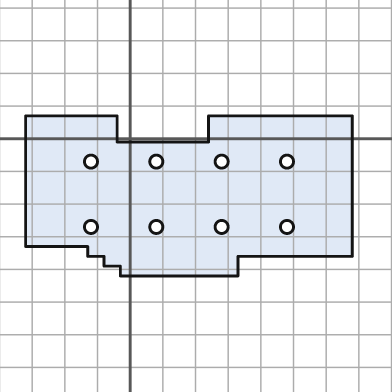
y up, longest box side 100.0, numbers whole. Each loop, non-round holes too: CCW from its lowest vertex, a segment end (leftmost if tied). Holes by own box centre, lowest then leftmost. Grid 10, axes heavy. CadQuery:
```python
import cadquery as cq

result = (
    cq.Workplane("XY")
    .moveTo(-3.0, -42.0)
    .lineTo(33.0, -42.0)
    .lineTo(33.0, -36.0)
    .lineTo(68.0, -36.0)
    .lineTo(68.0, 7.0)
    .lineTo(24.0, 7.0)
    .lineTo(24.0, -1.0)
    .lineTo(-4.0, -1.0)
    .lineTo(-4.0, 7.0)
    .lineTo(-32.0, 7.0)
    .lineTo(-32.0, -33.0)
    .lineTo(-13.0, -33.0)
    .lineTo(-13.0, -36.0)
    .lineTo(-8.0, -36.0)
    .lineTo(-8.0, -39.0)
    .lineTo(-3.0, -39.0)
    .close()
    .moveTo(-12.0, -27.0)
    .circle(2.0)
    .moveTo(8.0, -27.0)
    .circle(2.0)
    .moveTo(28.0, -27.0)
    .circle(2.0)
    .moveTo(48.0, -27.0)
    .circle(2.0)
    .moveTo(-12.0, -7.0)
    .circle(2.0)
    .moveTo(8.0, -7.0)
    .circle(2.0)
    .moveTo(28.0, -7.0)
    .circle(2.0)
    .moveTo(48.0, -7.0)
    .circle(2.0)
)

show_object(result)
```